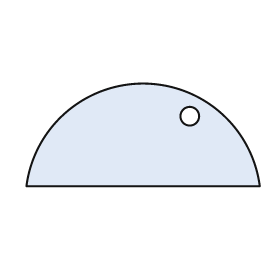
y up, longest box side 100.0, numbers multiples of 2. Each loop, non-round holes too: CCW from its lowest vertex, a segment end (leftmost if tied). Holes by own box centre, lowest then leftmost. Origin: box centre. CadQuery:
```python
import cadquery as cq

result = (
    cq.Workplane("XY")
    .moveTo(-50.0, -22.0)
    .lineTo(50.0, -22.0)
    .threePointArc((0.0, 22.0), (-50.0, -22.0))
    .close()
    .moveTo(20.0, 8.0)
    .circle(4.0)
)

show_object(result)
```